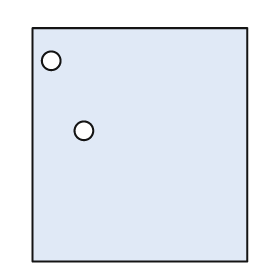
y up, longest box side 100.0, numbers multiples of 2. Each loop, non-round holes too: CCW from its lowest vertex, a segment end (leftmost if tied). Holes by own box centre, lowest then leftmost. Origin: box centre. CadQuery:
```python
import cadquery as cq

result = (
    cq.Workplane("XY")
    .moveTo(-46.0, -50.0)
    .lineTo(46.0, -50.0)
    .lineTo(46.0, 50.0)
    .lineTo(-46.0, 50.0)
    .close()
    .moveTo(-24.0, 6.0)
    .circle(4.0)
    .moveTo(-38.0, 36.0)
    .circle(4.0)
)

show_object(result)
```